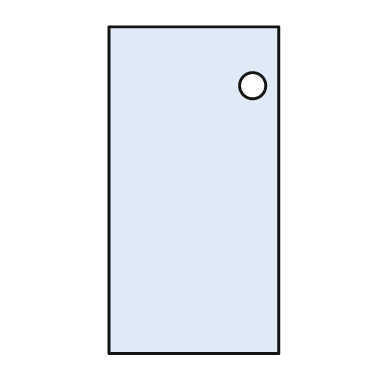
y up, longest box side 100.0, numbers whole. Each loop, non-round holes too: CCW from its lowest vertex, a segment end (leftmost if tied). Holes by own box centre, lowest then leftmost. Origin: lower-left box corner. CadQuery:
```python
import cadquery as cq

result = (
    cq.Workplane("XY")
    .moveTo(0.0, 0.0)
    .lineTo(52.0, 0.0)
    .lineTo(52.0, 100.0)
    .lineTo(0.0, 100.0)
    .close()
    .moveTo(44.0, 82.0)
    .circle(4.0)
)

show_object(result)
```